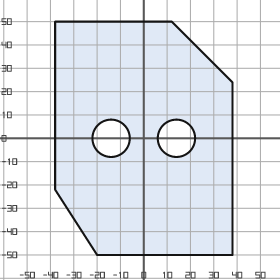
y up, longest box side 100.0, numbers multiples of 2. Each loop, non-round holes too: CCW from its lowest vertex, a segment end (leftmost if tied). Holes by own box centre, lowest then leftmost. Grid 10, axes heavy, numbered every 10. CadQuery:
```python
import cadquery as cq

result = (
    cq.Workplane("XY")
    .moveTo(-20.0, -50.0)
    .lineTo(38.0, -50.0)
    .lineTo(38.0, 24.0)
    .lineTo(12.0, 50.0)
    .lineTo(-38.0, 50.0)
    .lineTo(-38.0, -22.0)
    .close()
    .moveTo(-14.0, 0.0)
    .circle(8.0)
    .moveTo(14.0, 0.0)
    .circle(8.0)
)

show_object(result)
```